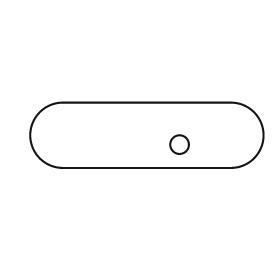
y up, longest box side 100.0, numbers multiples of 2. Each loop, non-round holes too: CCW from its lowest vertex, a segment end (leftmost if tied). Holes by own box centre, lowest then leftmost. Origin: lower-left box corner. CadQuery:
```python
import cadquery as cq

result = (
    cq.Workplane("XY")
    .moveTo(14.0, 0.0)
    .lineTo(86.0, 0.0)
    .threePointArc((100.0, 14.0), (86.0, 28.0))
    .lineTo(14.0, 28.0)
    .threePointArc((0.0, 14.0), (14.0, 0.0))
    .close()
    .moveTo(64.0, 10.0)
    .circle(4.0)
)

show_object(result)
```